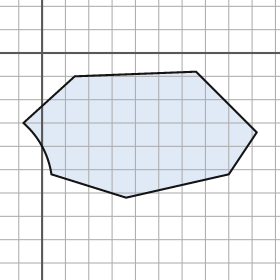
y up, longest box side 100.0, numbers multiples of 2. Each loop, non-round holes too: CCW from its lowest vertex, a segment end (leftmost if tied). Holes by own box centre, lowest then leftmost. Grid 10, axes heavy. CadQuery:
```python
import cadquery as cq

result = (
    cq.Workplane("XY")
    .moveTo(36.0, -62.0)
    .lineTo(80.0, -52.0)
    .lineTo(92.0, -34.0)
    .lineTo(66.0, -8.0)
    .lineTo(14.0, -10.0)
    .lineTo(-8.0, -30.0)
    .threePointArc((0.0, -40.0), (4.0, -52.0))
    .close()
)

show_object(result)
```